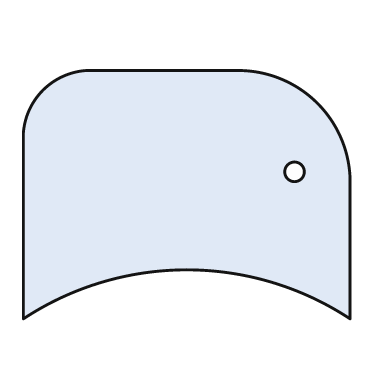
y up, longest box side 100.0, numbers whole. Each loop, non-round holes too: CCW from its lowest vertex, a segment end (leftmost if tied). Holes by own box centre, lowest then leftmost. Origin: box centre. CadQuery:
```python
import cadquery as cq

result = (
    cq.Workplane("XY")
    .moveTo(-50.0, -38.0)
    .threePointArc((0.0, -23.0), (50.0, -38.0))
    .lineTo(50.0, 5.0)
    .threePointArc((40.0, 28.0), (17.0, 38.0))
    .lineTo(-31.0, 38.0)
    .threePointArc((-44.0, 32.0), (-50.0, 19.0))
    .close()
    .moveTo(33.0, 7.0)
    .circle(3.0)
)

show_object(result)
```